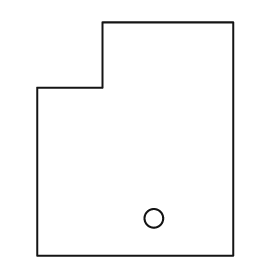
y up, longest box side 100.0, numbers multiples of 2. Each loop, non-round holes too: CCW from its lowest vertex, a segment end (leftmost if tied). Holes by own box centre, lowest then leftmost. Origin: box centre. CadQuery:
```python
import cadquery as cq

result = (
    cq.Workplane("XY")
    .moveTo(-42.0, -50.0)
    .lineTo(42.0, -50.0)
    .lineTo(42.0, 50.0)
    .lineTo(-14.0, 50.0)
    .lineTo(-14.0, 22.0)
    .lineTo(-42.0, 22.0)
    .close()
    .moveTo(8.0, -34.0)
    .circle(4.0)
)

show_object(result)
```